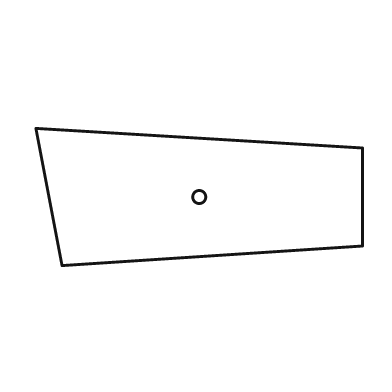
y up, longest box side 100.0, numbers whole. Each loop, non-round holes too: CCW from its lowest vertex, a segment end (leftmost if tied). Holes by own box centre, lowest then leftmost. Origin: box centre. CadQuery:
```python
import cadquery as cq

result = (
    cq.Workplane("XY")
    .moveTo(-42.0, -21.0)
    .lineTo(50.0, -15.0)
    .lineTo(50.0, 15.0)
    .lineTo(-50.0, 21.0)
    .close()
    .moveTo(0.0, 0.0)
    .circle(2.0)
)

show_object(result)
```